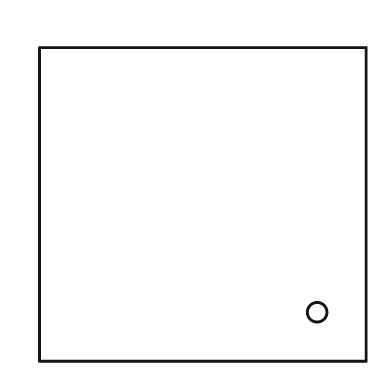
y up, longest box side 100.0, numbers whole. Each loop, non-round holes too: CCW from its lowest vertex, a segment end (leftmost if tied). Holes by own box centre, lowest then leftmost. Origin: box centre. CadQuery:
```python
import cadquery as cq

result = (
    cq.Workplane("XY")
    .moveTo(-50.0, -48.0)
    .lineTo(50.0, -48.0)
    .lineTo(50.0, 48.0)
    .lineTo(-50.0, 48.0)
    .close()
    .moveTo(35.0, -33.0)
    .circle(3.0)
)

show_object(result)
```